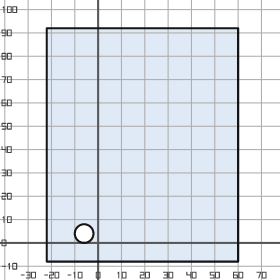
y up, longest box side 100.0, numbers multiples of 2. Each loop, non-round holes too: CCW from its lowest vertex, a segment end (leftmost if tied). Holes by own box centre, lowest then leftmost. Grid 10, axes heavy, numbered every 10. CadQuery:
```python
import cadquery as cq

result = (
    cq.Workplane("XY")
    .moveTo(-22.0, -8.0)
    .lineTo(60.0, -8.0)
    .lineTo(60.0, 92.0)
    .lineTo(-22.0, 92.0)
    .close()
    .moveTo(-6.0, 4.0)
    .circle(4.0)
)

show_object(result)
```